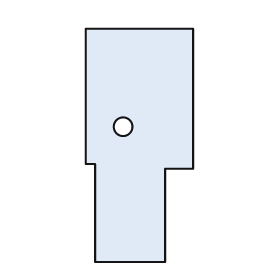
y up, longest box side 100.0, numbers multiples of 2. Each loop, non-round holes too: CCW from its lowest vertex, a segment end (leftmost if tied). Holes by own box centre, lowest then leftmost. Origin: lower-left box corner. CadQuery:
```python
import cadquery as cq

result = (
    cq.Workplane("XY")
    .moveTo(4.0, 0.0)
    .lineTo(34.0, 0.0)
    .lineTo(34.0, 40.0)
    .lineTo(46.0, 40.0)
    .lineTo(46.0, 100.0)
    .lineTo(0.0, 100.0)
    .lineTo(0.0, 42.0)
    .lineTo(4.0, 42.0)
    .close()
    .moveTo(16.0, 58.0)
    .circle(4.0)
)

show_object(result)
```